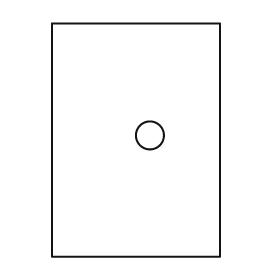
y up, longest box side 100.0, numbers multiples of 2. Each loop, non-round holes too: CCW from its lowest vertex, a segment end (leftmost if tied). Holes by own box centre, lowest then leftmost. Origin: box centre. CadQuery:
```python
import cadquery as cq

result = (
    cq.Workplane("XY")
    .moveTo(-36.0, -50.0)
    .lineTo(36.0, -50.0)
    .lineTo(36.0, 50.0)
    .lineTo(-36.0, 50.0)
    .close()
    .moveTo(6.0, 2.0)
    .circle(6.0)
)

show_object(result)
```